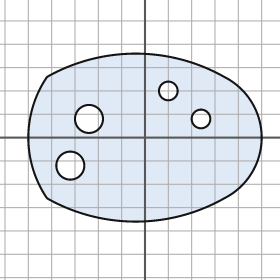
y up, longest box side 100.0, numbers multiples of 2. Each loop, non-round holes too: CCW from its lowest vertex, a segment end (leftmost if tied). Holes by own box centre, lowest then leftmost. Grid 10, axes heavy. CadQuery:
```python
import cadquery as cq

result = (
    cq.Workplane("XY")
    .moveTo(-42.0, -26.0)
    .threePointArc((-4.0, -36.0), (34.0, -26.0))
    .threePointArc((50.0, 0.0), (34.0, 26.0))
    .threePointArc((-4.0, 36.0), (-42.0, 26.0))
    .threePointArc((-50.0, 0.0), (-42.0, -26.0))
    .close()
    .moveTo(-32.0, -12.0)
    .circle(6.0)
    .moveTo(-24.0, 8.0)
    .circle(6.0)
    .moveTo(24.0, 8.0)
    .circle(4.0)
    .moveTo(10.0, 20.0)
    .circle(4.0)
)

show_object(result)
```